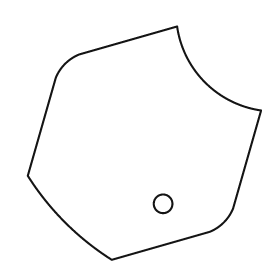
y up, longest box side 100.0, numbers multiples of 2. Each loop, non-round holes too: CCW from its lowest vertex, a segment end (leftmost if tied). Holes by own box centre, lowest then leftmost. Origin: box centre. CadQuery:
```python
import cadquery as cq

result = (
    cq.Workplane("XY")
    .moveTo(-14.0, -50.0)
    .lineTo(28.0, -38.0)
    .threePointArc((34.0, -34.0), (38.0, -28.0))
    .lineTo(50.0, 14.0)
    .threePointArc((26.0, 26.0), (14.0, 50.0))
    .lineTo(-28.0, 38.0)
    .threePointArc((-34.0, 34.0), (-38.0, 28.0))
    .lineTo(-50.0, -14.0)
    .threePointArc((-34.0, -34.0), (-14.0, -50.0))
    .close()
    .moveTo(8.0, -26.0)
    .circle(4.0)
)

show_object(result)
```